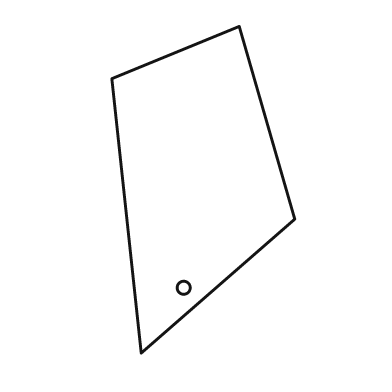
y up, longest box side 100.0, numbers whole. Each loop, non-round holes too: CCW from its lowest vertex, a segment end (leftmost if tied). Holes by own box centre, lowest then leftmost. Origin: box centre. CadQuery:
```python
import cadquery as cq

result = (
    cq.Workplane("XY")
    .moveTo(-19.0, -50.0)
    .lineTo(28.0, -9.0)
    .lineTo(11.0, 50.0)
    .lineTo(-28.0, 34.0)
    .close()
    .moveTo(-6.0, -30.0)
    .circle(2.0)
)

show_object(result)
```